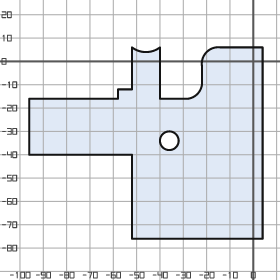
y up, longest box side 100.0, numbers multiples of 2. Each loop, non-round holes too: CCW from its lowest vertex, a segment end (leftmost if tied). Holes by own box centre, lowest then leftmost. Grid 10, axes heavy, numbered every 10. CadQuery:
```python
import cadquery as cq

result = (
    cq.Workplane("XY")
    .moveTo(-52.0, -76.0)
    .lineTo(4.0, -76.0)
    .lineTo(4.0, 6.0)
    .lineTo(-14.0, 6.0)
    .threePointArc((-20.0, 4.0), (-22.0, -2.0))
    .lineTo(-22.0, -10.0)
    .threePointArc((-24.0, -14.0), (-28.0, -16.0))
    .lineTo(-40.0, -16.0)
    .lineTo(-40.0, 6.0)
    .threePointArc((-46.0, 4.0), (-52.0, 6.0))
    .lineTo(-52.0, -12.0)
    .lineTo(-58.0, -12.0)
    .lineTo(-58.0, -16.0)
    .lineTo(-96.0, -16.0)
    .lineTo(-96.0, -40.0)
    .lineTo(-52.0, -40.0)
    .close()
    .moveTo(-36.0, -34.0)
    .circle(4.0)
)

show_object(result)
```